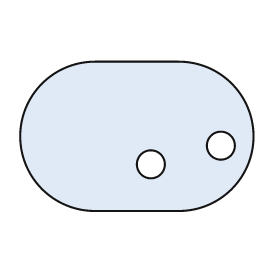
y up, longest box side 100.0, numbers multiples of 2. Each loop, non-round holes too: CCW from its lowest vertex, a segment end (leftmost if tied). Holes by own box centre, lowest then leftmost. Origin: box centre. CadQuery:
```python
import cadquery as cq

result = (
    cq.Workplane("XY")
    .moveTo(-18.0, -32.0)
    .lineTo(18.0, -32.0)
    .threePointArc((50.0, 0.0), (18.0, 32.0))
    .lineTo(-18.0, 32.0)
    .threePointArc((-50.0, 0.0), (-18.0, -32.0))
    .close()
    .moveTo(6.0, -12.0)
    .circle(6.0)
    .moveTo(36.0, -4.0)
    .circle(6.0)
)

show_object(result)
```